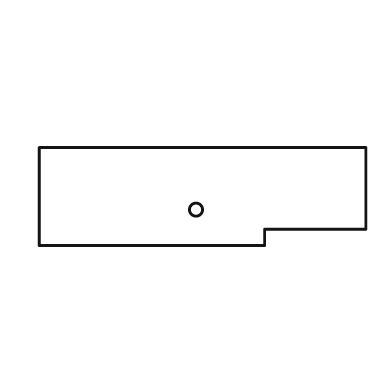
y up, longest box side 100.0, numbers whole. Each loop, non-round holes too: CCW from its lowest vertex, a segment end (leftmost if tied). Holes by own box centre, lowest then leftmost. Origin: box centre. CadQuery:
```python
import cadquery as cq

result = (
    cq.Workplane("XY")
    .moveTo(-50.0, -15.0)
    .lineTo(19.0, -15.0)
    .lineTo(19.0, -10.0)
    .lineTo(50.0, -10.0)
    .lineTo(50.0, 15.0)
    .lineTo(-50.0, 15.0)
    .close()
    .moveTo(-2.0, -4.0)
    .circle(2.0)
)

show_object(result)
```